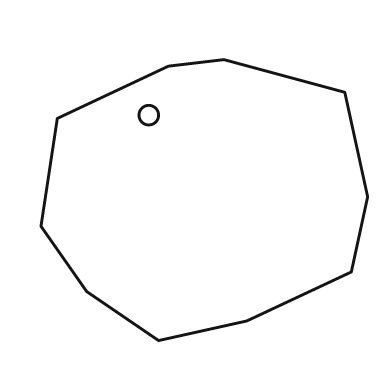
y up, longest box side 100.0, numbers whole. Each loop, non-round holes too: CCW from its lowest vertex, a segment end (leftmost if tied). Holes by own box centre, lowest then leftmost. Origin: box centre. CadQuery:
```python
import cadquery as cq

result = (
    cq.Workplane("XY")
    .moveTo(-14.0, -43.0)
    .lineTo(13.0, -37.0)
    .lineTo(45.0, -22.0)
    .lineTo(50.0, 1.0)
    .lineTo(43.0, 33.0)
    .lineTo(6.0, 43.0)
    .lineTo(-11.0, 41.0)
    .lineTo(-45.0, 25.0)
    .lineTo(-50.0, -8.0)
    .lineTo(-36.0, -28.0)
    .close()
    .moveTo(-17.0, 26.0)
    .circle(3.0)
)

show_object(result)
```